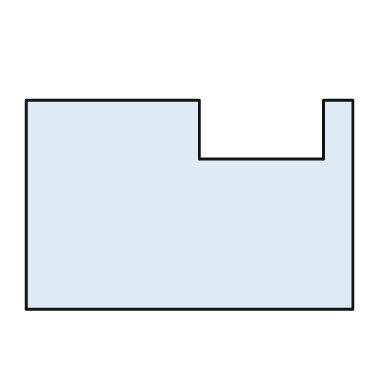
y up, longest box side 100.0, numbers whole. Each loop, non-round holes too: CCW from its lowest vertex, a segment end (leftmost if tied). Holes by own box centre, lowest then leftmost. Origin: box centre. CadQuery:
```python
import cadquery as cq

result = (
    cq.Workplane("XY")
    .moveTo(-50.0, -32.0)
    .lineTo(50.0, -32.0)
    .lineTo(50.0, 32.0)
    .lineTo(41.0, 32.0)
    .lineTo(41.0, 14.0)
    .lineTo(3.0, 14.0)
    .lineTo(3.0, 32.0)
    .lineTo(-50.0, 32.0)
    .close()
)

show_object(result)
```